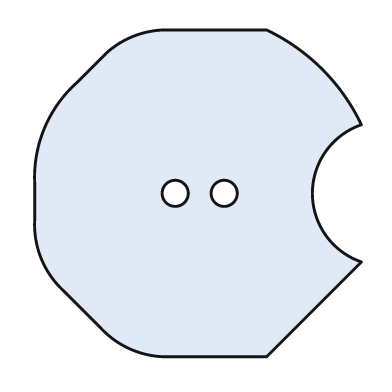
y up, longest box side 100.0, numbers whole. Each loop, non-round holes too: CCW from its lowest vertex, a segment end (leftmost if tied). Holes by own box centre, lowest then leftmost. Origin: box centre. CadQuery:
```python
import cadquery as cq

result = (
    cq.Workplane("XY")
    .moveTo(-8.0, -50.0)
    .lineTo(21.0, -50.0)
    .lineTo(50.0, -21.0)
    .threePointArc((35.0, 0.0), (50.0, 21.0))
    .threePointArc((38.0, 38.0), (21.0, 50.0))
    .lineTo(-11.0, 50.0)
    .threePointArc((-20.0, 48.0), (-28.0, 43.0))
    .lineTo(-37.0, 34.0)
    .threePointArc((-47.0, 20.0), (-50.0, 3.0))
    .lineTo(-50.0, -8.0)
    .threePointArc((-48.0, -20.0), (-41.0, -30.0))
    .lineTo(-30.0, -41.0)
    .threePointArc((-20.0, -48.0), (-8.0, -50.0))
    .close()
    .moveTo(-7.0, 0.0)
    .circle(4.0)
    .moveTo(8.0, 0.0)
    .circle(4.0)
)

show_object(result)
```